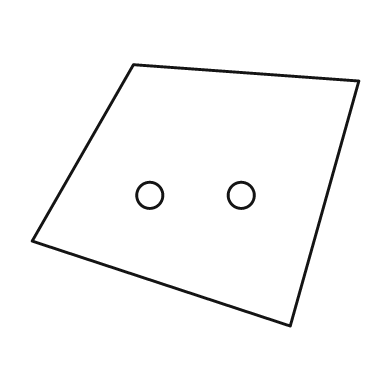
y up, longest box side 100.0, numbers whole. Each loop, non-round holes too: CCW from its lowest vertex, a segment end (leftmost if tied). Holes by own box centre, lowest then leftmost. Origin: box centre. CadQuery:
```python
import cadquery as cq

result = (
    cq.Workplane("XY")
    .moveTo(29.0, -40.0)
    .lineTo(50.0, 35.0)
    .lineTo(-19.0, 40.0)
    .lineTo(-50.0, -14.0)
    .close()
    .moveTo(-14.0, 0.0)
    .circle(4.0)
    .moveTo(14.0, 0.0)
    .circle(4.0)
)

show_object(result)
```